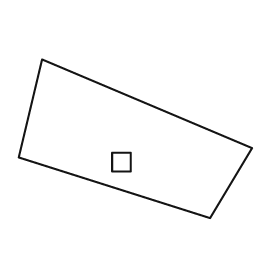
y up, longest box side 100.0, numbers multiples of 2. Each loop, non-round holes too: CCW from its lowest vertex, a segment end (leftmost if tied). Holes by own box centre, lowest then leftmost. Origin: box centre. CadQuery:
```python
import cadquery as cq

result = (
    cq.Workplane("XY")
    .moveTo(32.0, -34.0)
    .lineTo(50.0, -4.0)
    .lineTo(-40.0, 34.0)
    .lineTo(-50.0, -8.0)
    .close()
    .moveTo(-10.0, -14.0)
    .lineTo(-2.0, -14.0)
    .lineTo(-2.0, -6.0)
    .lineTo(-10.0, -6.0)
    .close()
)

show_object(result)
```